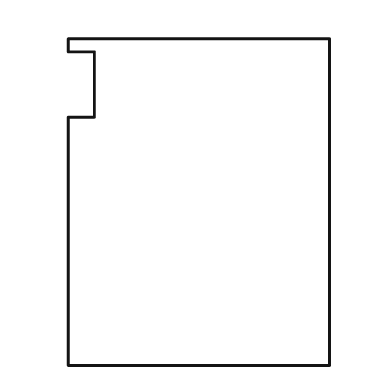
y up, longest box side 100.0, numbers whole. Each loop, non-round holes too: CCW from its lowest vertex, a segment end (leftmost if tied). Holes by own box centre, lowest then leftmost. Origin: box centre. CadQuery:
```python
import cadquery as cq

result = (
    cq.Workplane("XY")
    .moveTo(-40.0, -50.0)
    .lineTo(40.0, -50.0)
    .lineTo(40.0, 50.0)
    .lineTo(-40.0, 50.0)
    .lineTo(-40.0, 46.0)
    .lineTo(-32.0, 46.0)
    .lineTo(-32.0, 26.0)
    .lineTo(-40.0, 26.0)
    .close()
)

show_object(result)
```